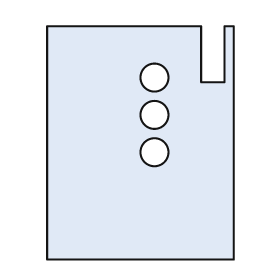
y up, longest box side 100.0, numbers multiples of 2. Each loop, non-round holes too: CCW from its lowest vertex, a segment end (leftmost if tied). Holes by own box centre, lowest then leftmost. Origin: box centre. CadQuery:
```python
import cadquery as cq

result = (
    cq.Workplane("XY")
    .moveTo(-40.0, -50.0)
    .lineTo(40.0, -50.0)
    .lineTo(40.0, 50.0)
    .lineTo(36.0, 50.0)
    .lineTo(36.0, 26.0)
    .lineTo(26.0, 26.0)
    .lineTo(26.0, 50.0)
    .lineTo(-40.0, 50.0)
    .close()
    .moveTo(6.0, -4.0)
    .circle(6.0)
    .moveTo(6.0, 12.0)
    .circle(6.0)
    .moveTo(6.0, 28.0)
    .circle(6.0)
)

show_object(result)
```